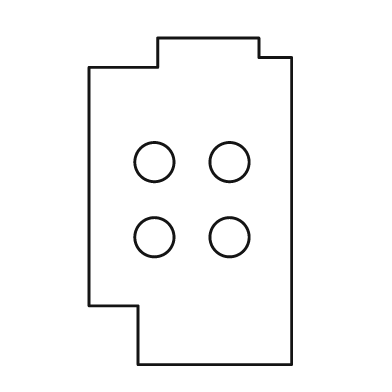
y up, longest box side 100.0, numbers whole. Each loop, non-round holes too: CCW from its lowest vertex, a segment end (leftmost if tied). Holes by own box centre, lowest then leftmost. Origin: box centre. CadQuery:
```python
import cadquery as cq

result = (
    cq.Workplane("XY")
    .moveTo(-16.0, -50.0)
    .lineTo(31.0, -50.0)
    .lineTo(31.0, 44.0)
    .lineTo(21.0, 44.0)
    .lineTo(21.0, 50.0)
    .lineTo(-10.0, 50.0)
    .lineTo(-10.0, 41.0)
    .lineTo(-31.0, 41.0)
    .lineTo(-31.0, -32.0)
    .lineTo(-16.0, -32.0)
    .close()
    .moveTo(-11.0, -11.0)
    .circle(6.0)
    .moveTo(12.0, -11.0)
    .circle(6.0)
    .moveTo(-11.0, 12.0)
    .circle(6.0)
    .moveTo(12.0, 12.0)
    .circle(6.0)
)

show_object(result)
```